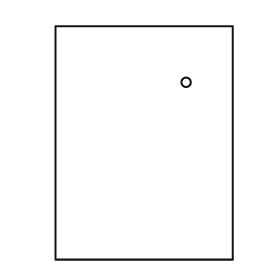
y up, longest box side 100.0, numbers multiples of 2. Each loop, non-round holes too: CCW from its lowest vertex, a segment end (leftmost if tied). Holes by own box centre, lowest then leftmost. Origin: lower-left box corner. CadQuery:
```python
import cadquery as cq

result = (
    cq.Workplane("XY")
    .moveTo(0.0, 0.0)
    .lineTo(76.0, 0.0)
    .lineTo(76.0, 100.0)
    .lineTo(0.0, 100.0)
    .close()
    .moveTo(56.0, 76.0)
    .circle(2.0)
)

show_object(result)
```